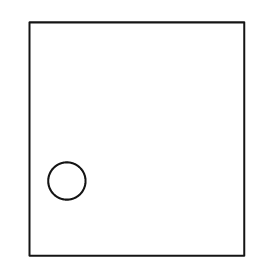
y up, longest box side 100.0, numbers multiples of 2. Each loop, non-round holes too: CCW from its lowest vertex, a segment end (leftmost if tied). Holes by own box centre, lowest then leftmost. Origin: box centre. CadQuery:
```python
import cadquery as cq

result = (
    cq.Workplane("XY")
    .moveTo(-46.0, -50.0)
    .lineTo(46.0, -50.0)
    .lineTo(46.0, 50.0)
    .lineTo(-46.0, 50.0)
    .close()
    .moveTo(-30.0, -18.0)
    .circle(8.0)
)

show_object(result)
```